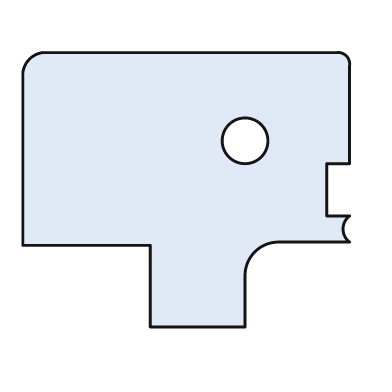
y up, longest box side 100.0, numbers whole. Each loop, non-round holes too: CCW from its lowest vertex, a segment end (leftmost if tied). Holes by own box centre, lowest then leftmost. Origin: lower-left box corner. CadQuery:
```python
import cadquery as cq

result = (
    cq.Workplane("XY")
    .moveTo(39.0, 0.0)
    .lineTo(68.0, 0.0)
    .lineTo(68.0, 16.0)
    .threePointArc((71.0, 23.0), (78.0, 26.0))
    .lineTo(100.0, 26.0)
    .threePointArc((98.0, 30.0), (100.0, 34.0))
    .lineTo(93.0, 34.0)
    .lineTo(93.0, 50.0)
    .lineTo(100.0, 50.0)
    .lineTo(100.0, 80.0)
    .threePointArc((99.0, 83.0), (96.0, 84.0))
    .lineTo(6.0, 84.0)
    .threePointArc((2.0, 82.0), (0.0, 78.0))
    .lineTo(0.0, 25.0)
    .lineTo(39.0, 25.0)
    .close()
    .moveTo(68.0, 57.0)
    .circle(7.0)
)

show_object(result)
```